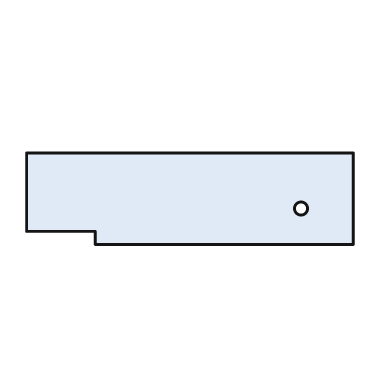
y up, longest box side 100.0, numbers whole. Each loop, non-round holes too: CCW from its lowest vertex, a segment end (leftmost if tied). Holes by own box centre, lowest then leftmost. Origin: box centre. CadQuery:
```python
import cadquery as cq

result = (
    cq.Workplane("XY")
    .moveTo(-29.0, -14.0)
    .lineTo(50.0, -14.0)
    .lineTo(50.0, 14.0)
    .lineTo(-50.0, 14.0)
    .lineTo(-50.0, -10.0)
    .lineTo(-29.0, -10.0)
    .close()
    .moveTo(34.0, -3.0)
    .circle(2.0)
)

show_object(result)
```